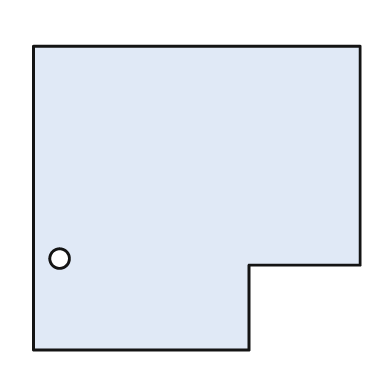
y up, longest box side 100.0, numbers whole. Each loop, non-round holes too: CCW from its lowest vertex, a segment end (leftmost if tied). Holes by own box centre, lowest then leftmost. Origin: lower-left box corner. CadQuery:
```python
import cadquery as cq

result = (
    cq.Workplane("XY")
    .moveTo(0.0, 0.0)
    .lineTo(66.0, 0.0)
    .lineTo(66.0, 26.0)
    .lineTo(100.0, 26.0)
    .lineTo(100.0, 93.0)
    .lineTo(0.0, 93.0)
    .close()
    .moveTo(8.0, 28.0)
    .circle(3.0)
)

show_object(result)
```